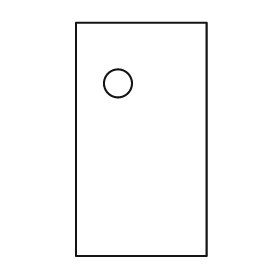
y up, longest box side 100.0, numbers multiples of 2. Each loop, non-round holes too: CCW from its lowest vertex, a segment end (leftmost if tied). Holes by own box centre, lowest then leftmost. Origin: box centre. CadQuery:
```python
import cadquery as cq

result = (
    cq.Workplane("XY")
    .moveTo(-28.0, -50.0)
    .lineTo(28.0, -50.0)
    .lineTo(28.0, 50.0)
    .lineTo(-28.0, 50.0)
    .close()
    .moveTo(-10.0, 24.0)
    .circle(6.0)
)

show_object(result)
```